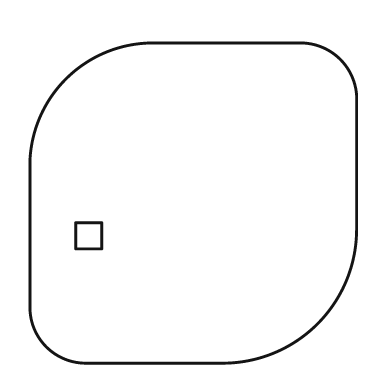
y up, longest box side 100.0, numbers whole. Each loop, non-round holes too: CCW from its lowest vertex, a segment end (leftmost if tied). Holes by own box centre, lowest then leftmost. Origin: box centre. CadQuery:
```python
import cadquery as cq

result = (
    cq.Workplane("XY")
    .moveTo(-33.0, -49.0)
    .lineTo(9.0, -49.0)
    .threePointArc((38.0, -37.0), (50.0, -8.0))
    .lineTo(50.0, 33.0)
    .threePointArc((45.0, 44.0), (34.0, 49.0))
    .lineTo(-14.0, 49.0)
    .threePointArc((-39.0, 38.0), (-50.0, 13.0))
    .lineTo(-50.0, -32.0)
    .threePointArc((-45.0, -44.0), (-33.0, -49.0))
    .close()
    .moveTo(-36.0, -14.0)
    .lineTo(-28.0, -14.0)
    .lineTo(-28.0, -6.0)
    .lineTo(-36.0, -6.0)
    .close()
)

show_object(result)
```